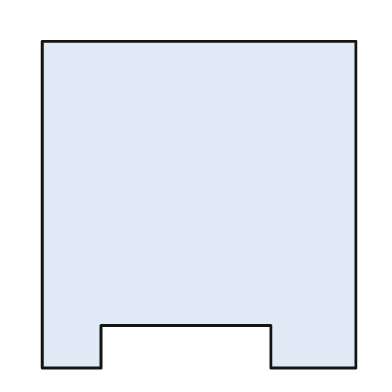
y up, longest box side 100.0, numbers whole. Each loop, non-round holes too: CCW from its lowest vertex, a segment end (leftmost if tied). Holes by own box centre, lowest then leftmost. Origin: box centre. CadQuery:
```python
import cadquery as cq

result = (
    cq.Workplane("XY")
    .moveTo(-48.0, -50.0)
    .lineTo(-30.0, -50.0)
    .lineTo(-30.0, -37.0)
    .lineTo(22.0, -37.0)
    .lineTo(22.0, -50.0)
    .lineTo(48.0, -50.0)
    .lineTo(48.0, 50.0)
    .lineTo(-48.0, 50.0)
    .close()
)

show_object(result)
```